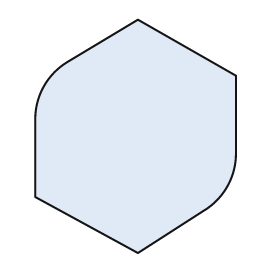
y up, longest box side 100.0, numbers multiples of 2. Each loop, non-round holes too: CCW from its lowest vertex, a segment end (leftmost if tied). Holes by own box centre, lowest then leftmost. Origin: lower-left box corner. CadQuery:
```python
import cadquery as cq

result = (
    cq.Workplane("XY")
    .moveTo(44.0, 0.0)
    .lineTo(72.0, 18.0)
    .threePointArc((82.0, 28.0), (86.0, 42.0))
    .lineTo(86.0, 76.0)
    .lineTo(44.0, 100.0)
    .lineTo(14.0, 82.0)
    .threePointArc((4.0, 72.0), (0.0, 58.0))
    .lineTo(0.0, 24.0)
    .close()
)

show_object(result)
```